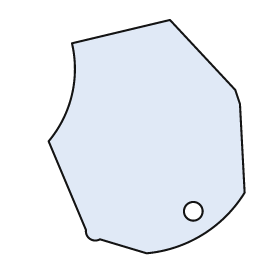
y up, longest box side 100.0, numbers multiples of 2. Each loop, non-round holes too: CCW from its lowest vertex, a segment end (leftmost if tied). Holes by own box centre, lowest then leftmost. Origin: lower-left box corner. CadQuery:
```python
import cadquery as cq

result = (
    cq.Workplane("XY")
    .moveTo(42.0, 0.0)
    .threePointArc((66.0, 8.0), (84.0, 26.0))
    .lineTo(82.0, 64.0)
    .lineTo(80.0, 70.0)
    .lineTo(52.0, 100.0)
    .lineTo(10.0, 90.0)
    .threePointArc((10.0, 68.0), (0.0, 48.0))
    .lineTo(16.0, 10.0)
    .threePointArc((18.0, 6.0), (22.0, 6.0))
    .close()
    .moveTo(62.0, 18.0)
    .circle(4.0)
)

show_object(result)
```